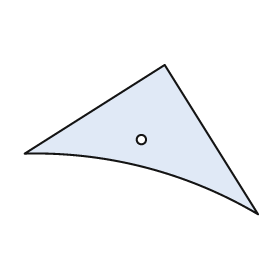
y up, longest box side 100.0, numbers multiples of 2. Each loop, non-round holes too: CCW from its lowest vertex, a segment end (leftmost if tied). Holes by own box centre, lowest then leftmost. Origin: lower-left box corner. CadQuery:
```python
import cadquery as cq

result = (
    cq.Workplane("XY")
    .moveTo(100.0, 0.0)
    .lineTo(60.0, 64.0)
    .lineTo(0.0, 26.0)
    .threePointArc((52.0, 20.0), (100.0, 0.0))
    .close()
    .moveTo(50.0, 32.0)
    .circle(2.0)
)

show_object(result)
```